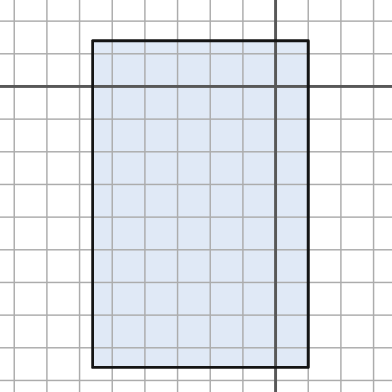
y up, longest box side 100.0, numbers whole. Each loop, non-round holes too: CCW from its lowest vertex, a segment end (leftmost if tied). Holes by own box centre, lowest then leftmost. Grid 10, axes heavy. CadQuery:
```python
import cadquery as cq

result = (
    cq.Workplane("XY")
    .moveTo(-56.0, -86.0)
    .lineTo(10.0, -86.0)
    .lineTo(10.0, 14.0)
    .lineTo(-56.0, 14.0)
    .close()
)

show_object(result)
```